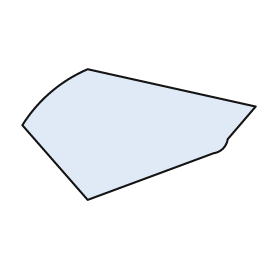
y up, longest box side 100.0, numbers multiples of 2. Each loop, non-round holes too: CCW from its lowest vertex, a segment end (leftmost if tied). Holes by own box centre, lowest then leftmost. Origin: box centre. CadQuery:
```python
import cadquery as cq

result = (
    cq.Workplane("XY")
    .moveTo(-22.0, -28.0)
    .lineTo(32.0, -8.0)
    .threePointArc((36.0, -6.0), (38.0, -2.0))
    .lineTo(50.0, 12.0)
    .lineTo(-22.0, 28.0)
    .threePointArc((-38.0, 18.0), (-50.0, 4.0))
    .close()
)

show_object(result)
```